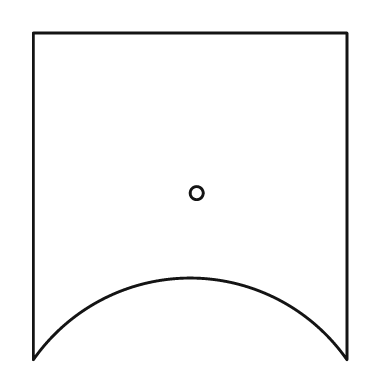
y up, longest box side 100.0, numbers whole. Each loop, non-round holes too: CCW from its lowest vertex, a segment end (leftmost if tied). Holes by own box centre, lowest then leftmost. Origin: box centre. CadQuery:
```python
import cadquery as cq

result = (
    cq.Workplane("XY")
    .moveTo(-48.0, -50.0)
    .threePointArc((0.0, -25.0), (48.0, -50.0))
    .lineTo(48.0, 50.0)
    .lineTo(-48.0, 50.0)
    .close()
    .moveTo(2.0, 1.0)
    .circle(2.0)
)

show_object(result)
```